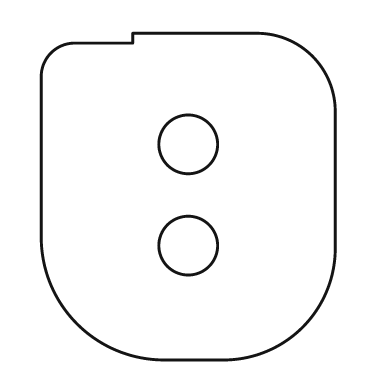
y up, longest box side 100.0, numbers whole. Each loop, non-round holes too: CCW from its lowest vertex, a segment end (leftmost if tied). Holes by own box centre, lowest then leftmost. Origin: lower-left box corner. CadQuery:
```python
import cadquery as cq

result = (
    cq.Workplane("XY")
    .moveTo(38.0, 0.0)
    .lineTo(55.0, 0.0)
    .threePointArc((80.0, 10.0), (90.0, 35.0))
    .lineTo(90.0, 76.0)
    .threePointArc((83.0, 93.0), (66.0, 100.0))
    .lineTo(28.0, 100.0)
    .lineTo(28.0, 97.0)
    .lineTo(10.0, 97.0)
    .threePointArc((3.0, 94.0), (0.0, 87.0))
    .lineTo(0.0, 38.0)
    .threePointArc((11.0, 11.0), (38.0, 0.0))
    .close()
    .moveTo(45.0, 35.0)
    .circle(9.0)
    .moveTo(45.0, 66.0)
    .circle(9.0)
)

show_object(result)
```